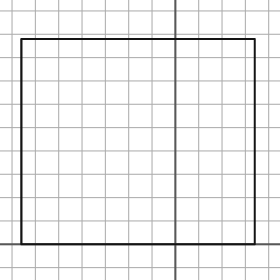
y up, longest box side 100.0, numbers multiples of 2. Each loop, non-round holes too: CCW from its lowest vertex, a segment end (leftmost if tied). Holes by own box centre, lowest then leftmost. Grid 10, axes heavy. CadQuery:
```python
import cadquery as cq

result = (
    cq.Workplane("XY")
    .moveTo(-66.0, 0.0)
    .lineTo(34.0, 0.0)
    .lineTo(34.0, 88.0)
    .lineTo(-66.0, 88.0)
    .close()
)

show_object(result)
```